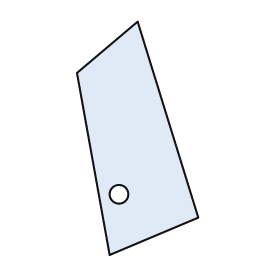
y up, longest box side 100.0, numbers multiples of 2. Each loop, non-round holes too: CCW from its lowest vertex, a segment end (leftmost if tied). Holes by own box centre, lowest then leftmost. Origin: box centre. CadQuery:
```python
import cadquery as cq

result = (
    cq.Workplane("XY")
    .moveTo(-12.0, -50.0)
    .lineTo(26.0, -34.0)
    .lineTo(0.0, 50.0)
    .lineTo(-26.0, 28.0)
    .close()
    .moveTo(-8.0, -24.0)
    .circle(4.0)
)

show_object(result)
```